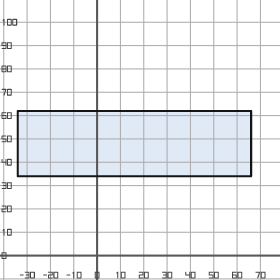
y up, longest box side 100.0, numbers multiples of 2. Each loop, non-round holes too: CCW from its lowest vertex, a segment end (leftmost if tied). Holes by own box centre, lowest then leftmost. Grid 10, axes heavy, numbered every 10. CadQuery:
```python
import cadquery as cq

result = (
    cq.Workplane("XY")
    .moveTo(-34.0, 34.0)
    .lineTo(66.0, 34.0)
    .lineTo(66.0, 62.0)
    .lineTo(-34.0, 62.0)
    .close()
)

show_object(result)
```